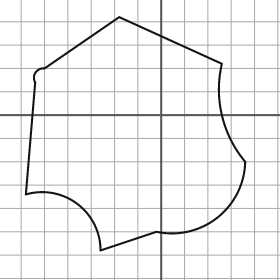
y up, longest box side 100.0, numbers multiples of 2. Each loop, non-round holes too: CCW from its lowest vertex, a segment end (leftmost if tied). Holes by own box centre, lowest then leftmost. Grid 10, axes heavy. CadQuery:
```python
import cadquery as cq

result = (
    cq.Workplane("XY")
    .moveTo(-26.0, -58.0)
    .lineTo(-2.0, -50.0)
    .threePointArc((24.0, -44.0), (36.0, -20.0))
    .threePointArc((26.0, 0.0), (26.0, 22.0))
    .lineTo(-18.0, 42.0)
    .lineTo(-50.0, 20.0)
    .threePointArc((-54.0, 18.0), (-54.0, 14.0))
    .lineTo(-58.0, -34.0)
    .threePointArc((-36.0, -38.0), (-26.0, -58.0))
    .close()
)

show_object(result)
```